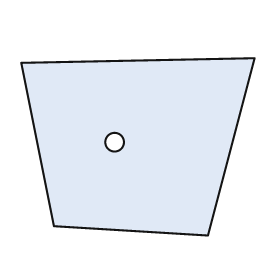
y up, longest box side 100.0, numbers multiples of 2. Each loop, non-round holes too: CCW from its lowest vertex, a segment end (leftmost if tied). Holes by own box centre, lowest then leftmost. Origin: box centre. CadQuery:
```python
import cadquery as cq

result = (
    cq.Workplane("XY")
    .moveTo(30.0, -38.0)
    .lineTo(50.0, 38.0)
    .lineTo(-50.0, 36.0)
    .lineTo(-36.0, -34.0)
    .close()
    .moveTo(-10.0, 2.0)
    .circle(4.0)
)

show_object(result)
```